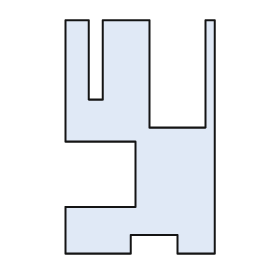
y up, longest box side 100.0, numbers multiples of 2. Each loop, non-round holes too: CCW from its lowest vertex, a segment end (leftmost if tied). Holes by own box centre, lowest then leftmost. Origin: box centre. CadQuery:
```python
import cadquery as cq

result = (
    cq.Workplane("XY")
    .moveTo(-32.0, -50.0)
    .lineTo(-4.0, -50.0)
    .lineTo(-4.0, -42.0)
    .lineTo(16.0, -42.0)
    .lineTo(16.0, -50.0)
    .lineTo(32.0, -50.0)
    .lineTo(32.0, 50.0)
    .lineTo(28.0, 50.0)
    .lineTo(28.0, 4.0)
    .lineTo(4.0, 4.0)
    .lineTo(4.0, 50.0)
    .lineTo(-16.0, 50.0)
    .lineTo(-16.0, 16.0)
    .lineTo(-22.0, 16.0)
    .lineTo(-22.0, 50.0)
    .lineTo(-32.0, 50.0)
    .lineTo(-32.0, -2.0)
    .lineTo(-2.0, -2.0)
    .lineTo(-2.0, -30.0)
    .lineTo(-32.0, -30.0)
    .close()
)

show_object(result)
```